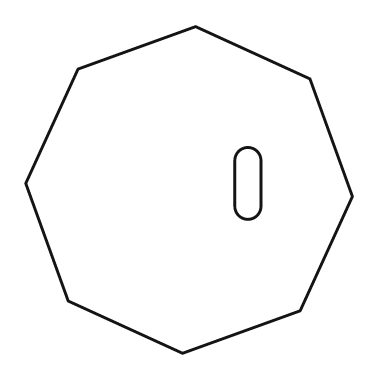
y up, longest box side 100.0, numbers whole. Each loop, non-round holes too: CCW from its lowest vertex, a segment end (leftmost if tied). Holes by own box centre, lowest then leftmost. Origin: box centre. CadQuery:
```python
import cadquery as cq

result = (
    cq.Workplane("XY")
    .moveTo(-2.0, -50.0)
    .lineTo(34.0, -37.0)
    .lineTo(50.0, -2.0)
    .lineTo(37.0, 34.0)
    .lineTo(2.0, 50.0)
    .lineTo(-34.0, 37.0)
    .lineTo(-50.0, 2.0)
    .lineTo(-37.0, -34.0)
    .close()
    .moveTo(14.0, -5.0)
    .threePointArc((18.0, -9.0), (22.0, -5.0))
    .lineTo(22.0, 9.0)
    .threePointArc((18.0, 13.0), (14.0, 9.0))
    .close()
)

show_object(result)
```